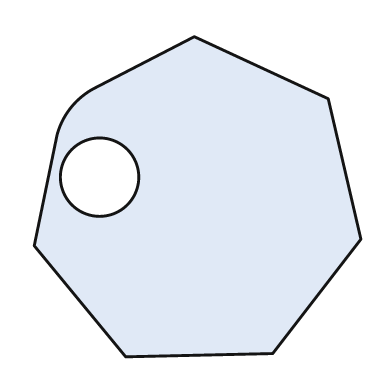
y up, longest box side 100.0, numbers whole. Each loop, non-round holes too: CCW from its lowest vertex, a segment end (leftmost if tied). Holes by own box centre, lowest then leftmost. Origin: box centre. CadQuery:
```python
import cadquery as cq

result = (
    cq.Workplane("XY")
    .moveTo(-22.0, -49.0)
    .lineTo(23.0, -48.0)
    .lineTo(50.0, -13.0)
    .lineTo(40.0, 30.0)
    .lineTo(-1.0, 49.0)
    .lineTo(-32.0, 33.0)
    .threePointArc((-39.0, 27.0), (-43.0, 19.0))
    .lineTo(-50.0, -15.0)
    .close()
    .moveTo(-30.0, 6.0)
    .circle(12.0)
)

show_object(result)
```